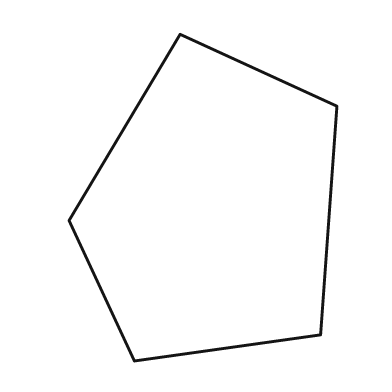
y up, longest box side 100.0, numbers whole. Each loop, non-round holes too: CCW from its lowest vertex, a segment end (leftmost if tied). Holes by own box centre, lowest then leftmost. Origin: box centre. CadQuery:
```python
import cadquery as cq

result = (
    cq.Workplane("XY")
    .moveTo(-21.0, -50.0)
    .lineTo(36.0, -42.0)
    .lineTo(41.0, 28.0)
    .lineTo(-7.0, 50.0)
    .lineTo(-41.0, -7.0)
    .close()
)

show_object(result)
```